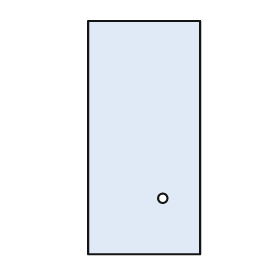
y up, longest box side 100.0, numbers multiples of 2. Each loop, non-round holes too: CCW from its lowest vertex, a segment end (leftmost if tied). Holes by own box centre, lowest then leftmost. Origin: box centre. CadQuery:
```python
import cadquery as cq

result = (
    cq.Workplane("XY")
    .moveTo(-24.0, -50.0)
    .lineTo(24.0, -50.0)
    .lineTo(24.0, 50.0)
    .lineTo(-24.0, 50.0)
    .close()
    .moveTo(8.0, -26.0)
    .circle(2.0)
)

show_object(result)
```